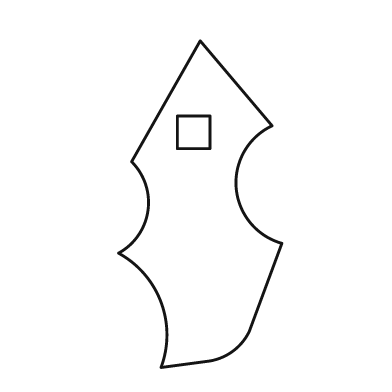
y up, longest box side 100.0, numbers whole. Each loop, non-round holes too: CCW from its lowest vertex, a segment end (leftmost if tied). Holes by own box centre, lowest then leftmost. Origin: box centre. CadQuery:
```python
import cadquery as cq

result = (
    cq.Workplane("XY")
    .moveTo(-12.0, -50.0)
    .lineTo(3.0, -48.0)
    .threePointArc((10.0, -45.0), (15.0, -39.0))
    .lineTo(25.0, -12.0)
    .threePointArc((11.0, 5.0), (22.0, 24.0))
    .lineTo(0.0, 50.0)
    .lineTo(-21.0, 13.0)
    .threePointArc((-16.0, -2.0), (-25.0, -15.0))
    .threePointArc((-12.0, -30.0), (-12.0, -50.0))
    .close()
    .moveTo(-7.0, 17.0)
    .lineTo(3.0, 17.0)
    .lineTo(3.0, 27.0)
    .lineTo(-7.0, 27.0)
    .close()
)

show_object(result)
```